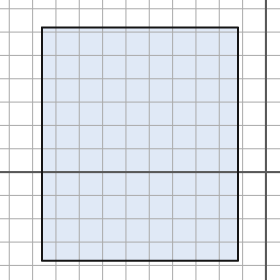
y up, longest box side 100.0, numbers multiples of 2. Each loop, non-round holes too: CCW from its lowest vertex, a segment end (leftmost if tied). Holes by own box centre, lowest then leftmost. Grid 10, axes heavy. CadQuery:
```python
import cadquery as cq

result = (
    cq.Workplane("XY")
    .moveTo(-96.0, -38.0)
    .lineTo(-12.0, -38.0)
    .lineTo(-12.0, 62.0)
    .lineTo(-96.0, 62.0)
    .close()
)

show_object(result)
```